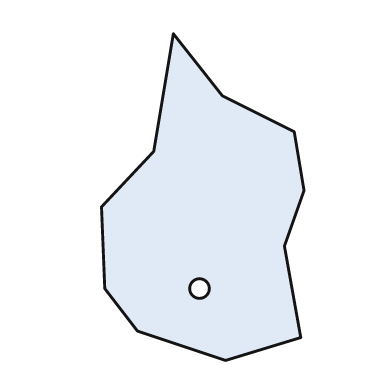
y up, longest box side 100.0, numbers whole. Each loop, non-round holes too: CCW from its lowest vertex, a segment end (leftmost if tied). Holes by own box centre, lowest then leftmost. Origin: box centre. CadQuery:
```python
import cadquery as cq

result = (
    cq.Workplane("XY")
    .moveTo(7.0, -50.0)
    .lineTo(30.0, -43.0)
    .lineTo(25.0, -15.0)
    .lineTo(31.0, 2.0)
    .lineTo(28.0, 20.0)
    .lineTo(6.0, 31.0)
    .lineTo(-9.0, 50.0)
    .lineTo(-15.0, 14.0)
    .lineTo(-31.0, -3.0)
    .lineTo(-30.0, -28.0)
    .lineTo(-20.0, -41.0)
    .close()
    .moveTo(-1.0, -28.0)
    .circle(3.0)
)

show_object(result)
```